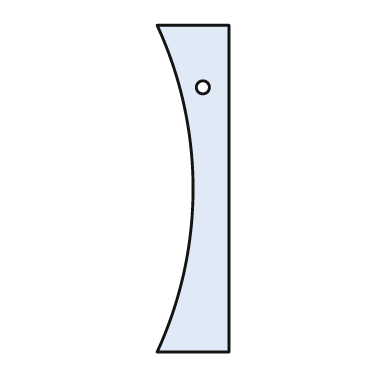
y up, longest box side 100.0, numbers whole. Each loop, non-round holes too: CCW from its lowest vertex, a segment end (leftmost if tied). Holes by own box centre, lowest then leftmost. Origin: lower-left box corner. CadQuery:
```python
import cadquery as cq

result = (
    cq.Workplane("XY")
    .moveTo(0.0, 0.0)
    .lineTo(22.0, 0.0)
    .lineTo(22.0, 100.0)
    .lineTo(0.0, 100.0)
    .threePointArc((11.0, 50.0), (0.0, 0.0))
    .close()
    .moveTo(14.0, 81.0)
    .circle(2.0)
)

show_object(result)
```